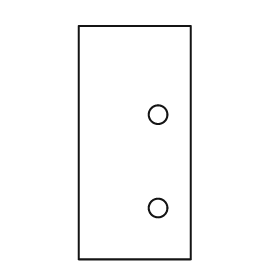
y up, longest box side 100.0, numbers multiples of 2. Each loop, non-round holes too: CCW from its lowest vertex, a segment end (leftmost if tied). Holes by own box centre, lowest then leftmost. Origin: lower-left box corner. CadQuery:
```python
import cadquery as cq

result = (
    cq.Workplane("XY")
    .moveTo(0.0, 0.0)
    .lineTo(48.0, 0.0)
    .lineTo(48.0, 100.0)
    .lineTo(0.0, 100.0)
    .close()
    .moveTo(34.0, 22.0)
    .circle(4.0)
    .moveTo(34.0, 62.0)
    .circle(4.0)
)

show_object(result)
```